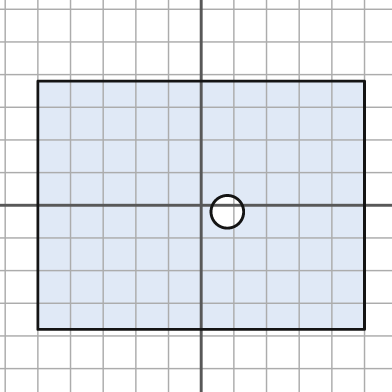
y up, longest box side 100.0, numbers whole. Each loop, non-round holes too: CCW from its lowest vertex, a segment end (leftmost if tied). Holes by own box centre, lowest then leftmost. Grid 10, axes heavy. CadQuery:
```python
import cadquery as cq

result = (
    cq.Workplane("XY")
    .moveTo(-50.0, -38.0)
    .lineTo(50.0, -38.0)
    .lineTo(50.0, 38.0)
    .lineTo(-50.0, 38.0)
    .close()
    .moveTo(8.0, -2.0)
    .circle(5.0)
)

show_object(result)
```